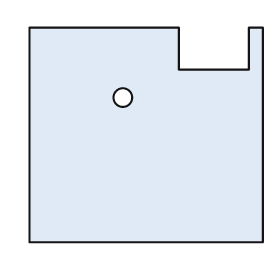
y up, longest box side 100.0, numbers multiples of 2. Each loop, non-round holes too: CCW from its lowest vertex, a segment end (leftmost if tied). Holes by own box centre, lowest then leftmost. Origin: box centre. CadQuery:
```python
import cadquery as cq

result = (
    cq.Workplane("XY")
    .moveTo(-50.0, -46.0)
    .lineTo(50.0, -46.0)
    .lineTo(50.0, 46.0)
    .lineTo(44.0, 46.0)
    .lineTo(44.0, 28.0)
    .lineTo(14.0, 28.0)
    .lineTo(14.0, 46.0)
    .lineTo(-50.0, 46.0)
    .close()
    .moveTo(-10.0, 16.0)
    .circle(4.0)
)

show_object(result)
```